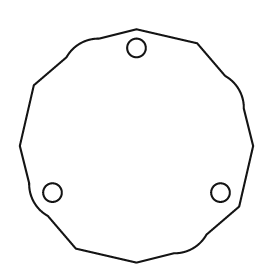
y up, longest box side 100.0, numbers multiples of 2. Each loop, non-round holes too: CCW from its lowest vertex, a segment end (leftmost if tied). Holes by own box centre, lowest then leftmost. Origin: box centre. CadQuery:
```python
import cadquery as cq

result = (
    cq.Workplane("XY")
    .moveTo(0.0, -50.0)
    .lineTo(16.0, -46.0)
    .threePointArc((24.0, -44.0), (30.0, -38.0))
    .lineTo(44.0, -26.0)
    .lineTo(50.0, 0.0)
    .lineTo(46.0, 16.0)
    .threePointArc((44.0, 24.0), (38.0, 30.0))
    .lineTo(26.0, 44.0)
    .lineTo(0.0, 50.0)
    .lineTo(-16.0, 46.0)
    .threePointArc((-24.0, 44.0), (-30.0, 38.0))
    .lineTo(-44.0, 26.0)
    .lineTo(-50.0, 0.0)
    .lineTo(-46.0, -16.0)
    .threePointArc((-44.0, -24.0), (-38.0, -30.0))
    .lineTo(-26.0, -44.0)
    .close()
    .moveTo(-36.0, -20.0)
    .circle(4.0)
    .moveTo(36.0, -20.0)
    .circle(4.0)
    .moveTo(0.0, 42.0)
    .circle(4.0)
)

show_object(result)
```